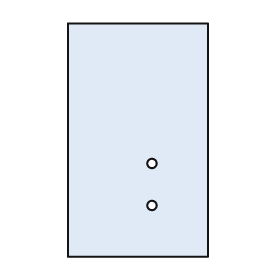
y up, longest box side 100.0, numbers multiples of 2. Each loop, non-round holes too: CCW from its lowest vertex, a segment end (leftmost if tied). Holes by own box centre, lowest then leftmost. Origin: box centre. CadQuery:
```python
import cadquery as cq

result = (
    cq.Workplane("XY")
    .moveTo(-30.0, -50.0)
    .lineTo(30.0, -50.0)
    .lineTo(30.0, 50.0)
    .lineTo(-30.0, 50.0)
    .close()
    .moveTo(6.0, -28.0)
    .circle(2.0)
    .moveTo(6.0, -10.0)
    .circle(2.0)
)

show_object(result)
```